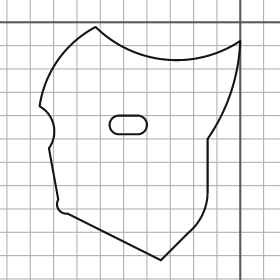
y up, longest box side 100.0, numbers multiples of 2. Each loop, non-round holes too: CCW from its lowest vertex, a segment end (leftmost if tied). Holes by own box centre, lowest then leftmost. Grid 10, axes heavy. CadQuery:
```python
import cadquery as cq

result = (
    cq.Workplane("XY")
    .moveTo(-34.0, -102.0)
    .lineTo(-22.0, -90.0)
    .threePointArc((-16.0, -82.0), (-14.0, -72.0))
    .lineTo(-14.0, -50.0)
    .threePointArc((-4.0, -30.0), (0.0, -8.0))
    .threePointArc((-32.0, -16.0), (-62.0, -2.0))
    .threePointArc((-78.0, -16.0), (-86.0, -36.0))
    .threePointArc((-80.0, -44.0), (-82.0, -54.0))
    .lineTo(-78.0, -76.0)
    .threePointArc((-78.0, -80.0), (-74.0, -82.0))
    .close()
    .moveTo(-52.0, -48.0)
    .lineTo(-44.0, -48.0)
    .threePointArc((-40.0, -44.0), (-44.0, -40.0))
    .lineTo(-52.0, -40.0)
    .threePointArc((-56.0, -44.0), (-52.0, -48.0))
    .close()
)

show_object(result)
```